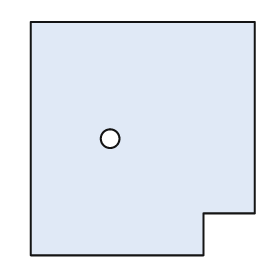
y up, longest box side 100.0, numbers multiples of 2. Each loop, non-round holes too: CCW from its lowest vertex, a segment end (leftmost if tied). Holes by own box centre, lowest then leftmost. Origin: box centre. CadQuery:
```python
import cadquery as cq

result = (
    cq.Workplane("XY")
    .moveTo(-48.0, -50.0)
    .lineTo(26.0, -50.0)
    .lineTo(26.0, -32.0)
    .lineTo(48.0, -32.0)
    .lineTo(48.0, 50.0)
    .lineTo(-48.0, 50.0)
    .close()
    .moveTo(-14.0, 0.0)
    .circle(4.0)
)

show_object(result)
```